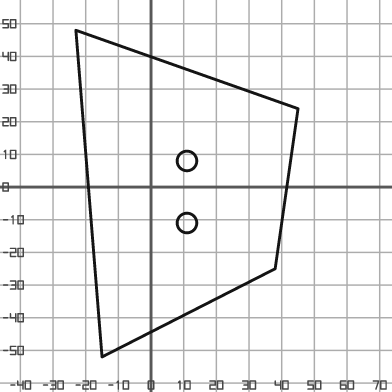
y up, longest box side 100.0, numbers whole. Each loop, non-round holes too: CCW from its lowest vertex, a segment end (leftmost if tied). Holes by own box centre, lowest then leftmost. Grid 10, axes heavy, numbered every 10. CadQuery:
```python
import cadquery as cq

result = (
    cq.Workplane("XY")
    .moveTo(-15.0, -52.0)
    .lineTo(38.0, -25.0)
    .lineTo(45.0, 24.0)
    .lineTo(-23.0, 48.0)
    .close()
    .moveTo(11.0, -11.0)
    .circle(3.0)
    .moveTo(11.0, 8.0)
    .circle(3.0)
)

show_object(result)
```